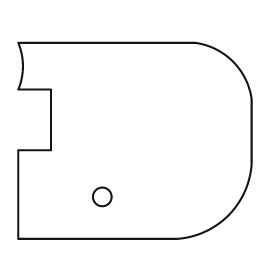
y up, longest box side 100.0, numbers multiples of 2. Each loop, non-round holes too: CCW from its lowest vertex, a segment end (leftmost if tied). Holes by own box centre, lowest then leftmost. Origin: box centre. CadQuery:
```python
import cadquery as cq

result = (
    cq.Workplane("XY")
    .moveTo(-50.0, -42.0)
    .lineTo(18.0, -42.0)
    .threePointArc((40.0, -32.0), (50.0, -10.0))
    .lineTo(50.0, 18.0)
    .threePointArc((42.0, 34.0), (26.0, 42.0))
    .lineTo(-50.0, 42.0)
    .threePointArc((-48.0, 32.0), (-50.0, 22.0))
    .lineTo(-36.0, 22.0)
    .lineTo(-36.0, -4.0)
    .lineTo(-50.0, -4.0)
    .close()
    .moveTo(-14.0, -24.0)
    .circle(4.0)
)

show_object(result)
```